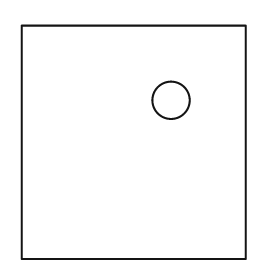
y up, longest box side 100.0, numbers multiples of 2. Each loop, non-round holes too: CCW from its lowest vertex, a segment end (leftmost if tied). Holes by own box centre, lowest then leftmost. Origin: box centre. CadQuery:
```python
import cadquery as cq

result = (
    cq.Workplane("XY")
    .moveTo(-48.0, -50.0)
    .lineTo(48.0, -50.0)
    .lineTo(48.0, 50.0)
    .lineTo(-48.0, 50.0)
    .close()
    .moveTo(16.0, 18.0)
    .circle(8.0)
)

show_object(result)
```